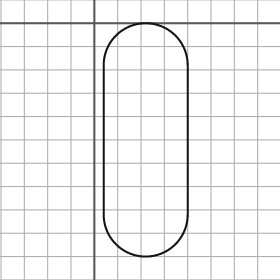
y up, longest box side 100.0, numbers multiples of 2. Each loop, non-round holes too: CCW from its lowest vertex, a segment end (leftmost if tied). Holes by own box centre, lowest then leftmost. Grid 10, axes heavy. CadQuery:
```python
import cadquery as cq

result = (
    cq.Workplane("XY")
    .moveTo(4.0, -82.0)
    .threePointArc((22.0, -100.0), (40.0, -82.0))
    .lineTo(40.0, -18.0)
    .threePointArc((22.0, 0.0), (4.0, -18.0))
    .close()
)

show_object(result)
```